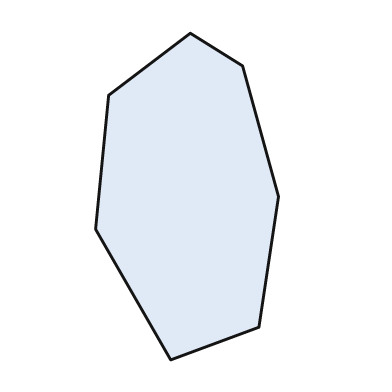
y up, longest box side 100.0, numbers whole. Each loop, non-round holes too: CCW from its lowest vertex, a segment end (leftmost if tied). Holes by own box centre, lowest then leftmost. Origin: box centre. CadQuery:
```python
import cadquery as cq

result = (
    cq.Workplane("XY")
    .moveTo(-5.0, -50.0)
    .lineTo(22.0, -40.0)
    .lineTo(28.0, 0.0)
    .lineTo(17.0, 40.0)
    .lineTo(1.0, 50.0)
    .lineTo(-24.0, 31.0)
    .lineTo(-28.0, -10.0)
    .close()
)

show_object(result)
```